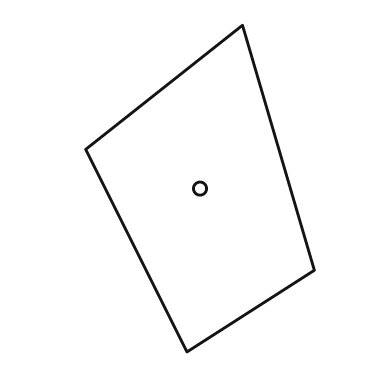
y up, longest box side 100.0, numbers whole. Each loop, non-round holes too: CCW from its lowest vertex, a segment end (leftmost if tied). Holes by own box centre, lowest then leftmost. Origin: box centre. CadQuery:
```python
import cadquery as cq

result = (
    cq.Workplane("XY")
    .moveTo(-4.0, -50.0)
    .lineTo(35.0, -25.0)
    .lineTo(13.0, 50.0)
    .lineTo(-35.0, 12.0)
    .close()
    .moveTo(0.0, 0.0)
    .circle(2.0)
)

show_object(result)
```